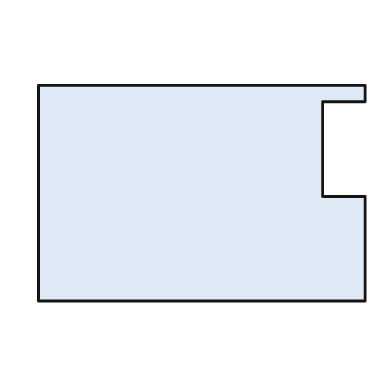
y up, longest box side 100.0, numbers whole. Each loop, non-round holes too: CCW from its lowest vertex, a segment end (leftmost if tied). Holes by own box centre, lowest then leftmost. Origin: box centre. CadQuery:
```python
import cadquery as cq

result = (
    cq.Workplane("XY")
    .moveTo(-50.0, -33.0)
    .lineTo(50.0, -33.0)
    .lineTo(50.0, -1.0)
    .lineTo(37.0, -1.0)
    .lineTo(37.0, 28.0)
    .lineTo(50.0, 28.0)
    .lineTo(50.0, 33.0)
    .lineTo(-50.0, 33.0)
    .close()
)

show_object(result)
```